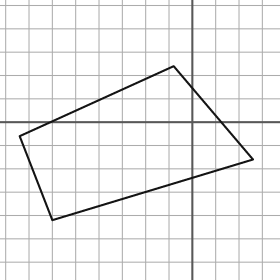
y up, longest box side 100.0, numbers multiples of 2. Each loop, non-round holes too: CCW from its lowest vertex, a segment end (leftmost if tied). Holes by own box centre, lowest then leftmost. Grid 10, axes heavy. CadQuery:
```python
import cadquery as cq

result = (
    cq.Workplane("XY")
    .moveTo(-60.0, -42.0)
    .lineTo(26.0, -16.0)
    .lineTo(-8.0, 24.0)
    .lineTo(-74.0, -6.0)
    .close()
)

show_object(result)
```